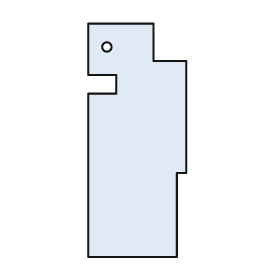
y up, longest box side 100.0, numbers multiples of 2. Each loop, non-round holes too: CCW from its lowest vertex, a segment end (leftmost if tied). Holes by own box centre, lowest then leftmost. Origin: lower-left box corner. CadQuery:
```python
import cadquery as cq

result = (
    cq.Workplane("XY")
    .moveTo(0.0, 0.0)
    .lineTo(38.0, 0.0)
    .lineTo(38.0, 36.0)
    .lineTo(42.0, 36.0)
    .lineTo(42.0, 84.0)
    .lineTo(28.0, 84.0)
    .lineTo(28.0, 100.0)
    .lineTo(0.0, 100.0)
    .lineTo(0.0, 78.0)
    .lineTo(12.0, 78.0)
    .lineTo(12.0, 70.0)
    .lineTo(0.0, 70.0)
    .close()
    .moveTo(8.0, 90.0)
    .circle(2.0)
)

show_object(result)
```